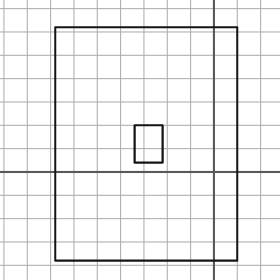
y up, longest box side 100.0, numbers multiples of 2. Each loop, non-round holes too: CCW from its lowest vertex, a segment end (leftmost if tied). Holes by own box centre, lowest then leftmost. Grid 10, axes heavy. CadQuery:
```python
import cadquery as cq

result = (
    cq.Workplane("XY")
    .moveTo(-68.0, -38.0)
    .lineTo(10.0, -38.0)
    .lineTo(10.0, 62.0)
    .lineTo(-68.0, 62.0)
    .close()
    .moveTo(-34.0, 4.0)
    .lineTo(-22.0, 4.0)
    .lineTo(-22.0, 20.0)
    .lineTo(-34.0, 20.0)
    .close()
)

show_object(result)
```